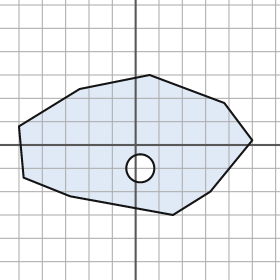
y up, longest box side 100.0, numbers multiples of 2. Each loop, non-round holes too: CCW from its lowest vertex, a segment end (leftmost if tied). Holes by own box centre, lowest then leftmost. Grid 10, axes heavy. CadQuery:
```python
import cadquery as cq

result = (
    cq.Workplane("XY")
    .moveTo(16.0, -30.0)
    .lineTo(32.0, -20.0)
    .lineTo(50.0, 2.0)
    .lineTo(38.0, 18.0)
    .lineTo(6.0, 30.0)
    .lineTo(-24.0, 24.0)
    .lineTo(-50.0, 8.0)
    .lineTo(-48.0, -14.0)
    .lineTo(-28.0, -22.0)
    .close()
    .moveTo(2.0, -10.0)
    .circle(6.0)
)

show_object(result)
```